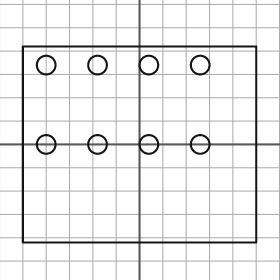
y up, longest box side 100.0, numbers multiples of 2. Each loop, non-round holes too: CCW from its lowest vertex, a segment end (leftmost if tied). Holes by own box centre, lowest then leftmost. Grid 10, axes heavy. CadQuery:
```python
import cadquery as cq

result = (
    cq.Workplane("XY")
    .moveTo(-50.0, -42.0)
    .lineTo(50.0, -42.0)
    .lineTo(50.0, 42.0)
    .lineTo(-50.0, 42.0)
    .close()
    .moveTo(-40.0, 0.0)
    .circle(4.0)
    .moveTo(-18.0, 0.0)
    .circle(4.0)
    .moveTo(4.0, 0.0)
    .circle(4.0)
    .moveTo(26.0, 0.0)
    .circle(4.0)
    .moveTo(-40.0, 34.0)
    .circle(4.0)
    .moveTo(-18.0, 34.0)
    .circle(4.0)
    .moveTo(4.0, 34.0)
    .circle(4.0)
    .moveTo(26.0, 34.0)
    .circle(4.0)
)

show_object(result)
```